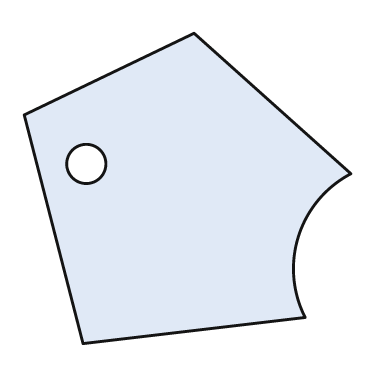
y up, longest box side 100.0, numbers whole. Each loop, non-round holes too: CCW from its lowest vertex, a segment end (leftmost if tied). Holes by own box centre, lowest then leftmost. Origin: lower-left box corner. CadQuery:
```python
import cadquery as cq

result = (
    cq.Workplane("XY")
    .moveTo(18.0, 0.0)
    .lineTo(86.0, 8.0)
    .threePointArc((84.0, 33.0), (100.0, 52.0))
    .lineTo(52.0, 95.0)
    .lineTo(0.0, 70.0)
    .close()
    .moveTo(19.0, 55.0)
    .circle(6.0)
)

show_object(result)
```